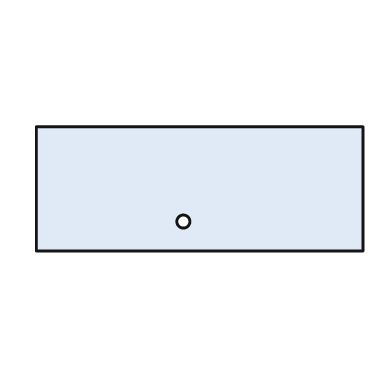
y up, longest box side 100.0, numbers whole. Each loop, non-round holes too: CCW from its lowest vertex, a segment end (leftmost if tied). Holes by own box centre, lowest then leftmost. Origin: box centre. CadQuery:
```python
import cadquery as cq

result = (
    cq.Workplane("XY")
    .moveTo(-50.0, -19.0)
    .lineTo(50.0, -19.0)
    .lineTo(50.0, 19.0)
    .lineTo(-50.0, 19.0)
    .close()
    .moveTo(-5.0, -10.0)
    .circle(2.0)
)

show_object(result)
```